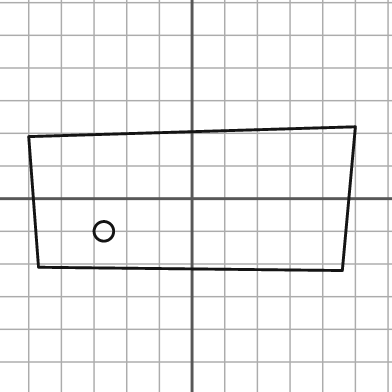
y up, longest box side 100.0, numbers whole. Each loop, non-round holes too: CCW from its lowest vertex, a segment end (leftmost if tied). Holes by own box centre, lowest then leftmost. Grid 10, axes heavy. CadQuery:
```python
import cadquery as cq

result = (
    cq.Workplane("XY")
    .moveTo(46.0, -22.0)
    .lineTo(50.0, 22.0)
    .lineTo(-50.0, 19.0)
    .lineTo(-47.0, -21.0)
    .close()
    .moveTo(-27.0, -10.0)
    .circle(3.0)
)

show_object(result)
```